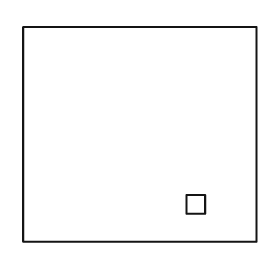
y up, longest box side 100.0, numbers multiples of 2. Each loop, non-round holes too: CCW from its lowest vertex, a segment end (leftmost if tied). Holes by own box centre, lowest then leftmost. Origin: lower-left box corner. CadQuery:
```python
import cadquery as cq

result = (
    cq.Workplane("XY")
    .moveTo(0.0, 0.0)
    .lineTo(100.0, 0.0)
    .lineTo(100.0, 92.0)
    .lineTo(0.0, 92.0)
    .close()
    .moveTo(70.0, 12.0)
    .lineTo(78.0, 12.0)
    .lineTo(78.0, 20.0)
    .lineTo(70.0, 20.0)
    .close()
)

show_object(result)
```